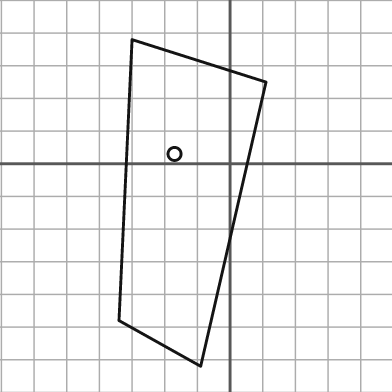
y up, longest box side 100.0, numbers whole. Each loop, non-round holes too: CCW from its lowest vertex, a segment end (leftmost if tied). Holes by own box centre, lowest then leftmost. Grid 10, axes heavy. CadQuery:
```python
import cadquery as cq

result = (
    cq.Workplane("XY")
    .moveTo(-9.0, -62.0)
    .lineTo(11.0, 25.0)
    .lineTo(-30.0, 38.0)
    .lineTo(-34.0, -48.0)
    .close()
    .moveTo(-17.0, 3.0)
    .circle(2.0)
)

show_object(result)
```